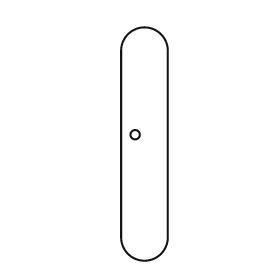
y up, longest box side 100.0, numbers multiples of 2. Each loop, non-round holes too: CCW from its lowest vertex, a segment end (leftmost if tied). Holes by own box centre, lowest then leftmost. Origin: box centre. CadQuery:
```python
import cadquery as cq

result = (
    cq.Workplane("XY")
    .moveTo(-10.0, -40.0)
    .threePointArc((0.0, -50.0), (10.0, -40.0))
    .lineTo(10.0, 40.0)
    .threePointArc((0.0, 50.0), (-10.0, 40.0))
    .close()
    .moveTo(-4.0, 4.0)
    .circle(2.0)
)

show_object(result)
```